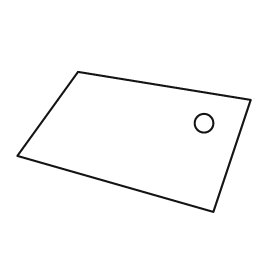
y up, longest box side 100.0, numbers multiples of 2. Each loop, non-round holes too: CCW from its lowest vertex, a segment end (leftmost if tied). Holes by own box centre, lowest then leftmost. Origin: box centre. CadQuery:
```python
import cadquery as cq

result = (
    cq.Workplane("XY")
    .moveTo(34.0, -30.0)
    .lineTo(50.0, 18.0)
    .lineTo(-24.0, 30.0)
    .lineTo(-50.0, -6.0)
    .close()
    .moveTo(30.0, 8.0)
    .circle(4.0)
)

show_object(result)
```